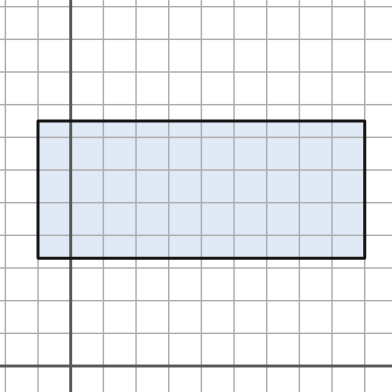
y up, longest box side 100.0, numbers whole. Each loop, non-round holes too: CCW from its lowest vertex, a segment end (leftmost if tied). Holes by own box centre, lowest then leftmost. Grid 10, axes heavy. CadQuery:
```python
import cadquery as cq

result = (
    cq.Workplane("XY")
    .moveTo(-10.0, 33.0)
    .lineTo(90.0, 33.0)
    .lineTo(90.0, 75.0)
    .lineTo(-10.0, 75.0)
    .close()
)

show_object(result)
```